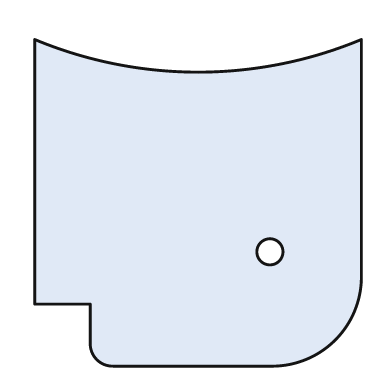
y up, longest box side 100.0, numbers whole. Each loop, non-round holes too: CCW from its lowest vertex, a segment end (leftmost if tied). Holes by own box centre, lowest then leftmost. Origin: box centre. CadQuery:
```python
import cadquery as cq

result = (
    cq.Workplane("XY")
    .moveTo(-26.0, -50.0)
    .lineTo(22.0, -50.0)
    .threePointArc((42.0, -42.0), (50.0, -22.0))
    .lineTo(50.0, 50.0)
    .threePointArc((0.0, 40.0), (-50.0, 50.0))
    .lineTo(-50.0, -31.0)
    .lineTo(-33.0, -31.0)
    .lineTo(-33.0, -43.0)
    .threePointArc((-31.0, -48.0), (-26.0, -50.0))
    .close()
    .moveTo(22.0, -15.0)
    .circle(4.0)
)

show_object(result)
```